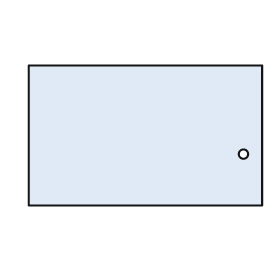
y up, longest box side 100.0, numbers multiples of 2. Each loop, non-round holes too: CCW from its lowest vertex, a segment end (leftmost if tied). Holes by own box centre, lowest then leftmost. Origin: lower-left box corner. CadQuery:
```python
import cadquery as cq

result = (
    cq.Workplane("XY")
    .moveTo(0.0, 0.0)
    .lineTo(100.0, 0.0)
    .lineTo(100.0, 60.0)
    .lineTo(0.0, 60.0)
    .close()
    .moveTo(92.0, 22.0)
    .circle(2.0)
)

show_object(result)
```